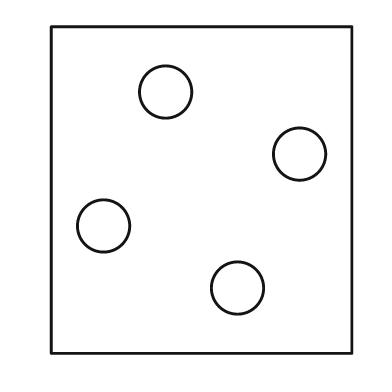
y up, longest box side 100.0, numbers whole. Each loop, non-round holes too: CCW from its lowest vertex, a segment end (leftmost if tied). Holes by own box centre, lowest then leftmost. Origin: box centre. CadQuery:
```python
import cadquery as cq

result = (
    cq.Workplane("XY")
    .moveTo(-46.0, -50.0)
    .lineTo(46.0, -50.0)
    .lineTo(46.0, 50.0)
    .lineTo(-46.0, 50.0)
    .close()
    .moveTo(11.0, -30.0)
    .circle(8.0)
    .moveTo(-30.0, -11.0)
    .circle(8.0)
    .moveTo(30.0, 11.0)
    .circle(8.0)
    .moveTo(-11.0, 30.0)
    .circle(8.0)
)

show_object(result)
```